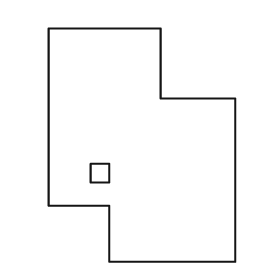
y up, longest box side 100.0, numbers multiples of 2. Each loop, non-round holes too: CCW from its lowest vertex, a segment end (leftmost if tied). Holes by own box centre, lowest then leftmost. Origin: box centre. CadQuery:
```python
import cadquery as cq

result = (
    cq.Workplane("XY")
    .moveTo(-14.0, -50.0)
    .lineTo(40.0, -50.0)
    .lineTo(40.0, 20.0)
    .lineTo(8.0, 20.0)
    .lineTo(8.0, 50.0)
    .lineTo(-40.0, 50.0)
    .lineTo(-40.0, -26.0)
    .lineTo(-14.0, -26.0)
    .close()
    .moveTo(-22.0, -16.0)
    .lineTo(-14.0, -16.0)
    .lineTo(-14.0, -8.0)
    .lineTo(-22.0, -8.0)
    .close()
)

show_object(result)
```